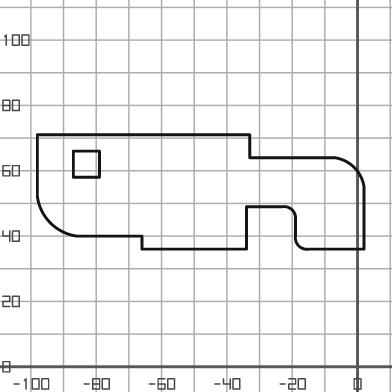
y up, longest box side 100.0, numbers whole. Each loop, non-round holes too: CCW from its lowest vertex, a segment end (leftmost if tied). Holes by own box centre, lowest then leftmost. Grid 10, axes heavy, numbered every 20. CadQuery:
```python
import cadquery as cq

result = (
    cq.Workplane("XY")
    .moveTo(-66.0, 36.0)
    .lineTo(-34.0, 36.0)
    .lineTo(-34.0, 49.0)
    .lineTo(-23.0, 49.0)
    .threePointArc((-20.0, 48.0), (-19.0, 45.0))
    .lineTo(-19.0, 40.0)
    .threePointArc((-18.0, 37.0), (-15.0, 36.0))
    .lineTo(2.0, 36.0)
    .lineTo(2.0, 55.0)
    .threePointArc((-1.0, 61.0), (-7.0, 64.0))
    .lineTo(-33.0, 64.0)
    .lineTo(-33.0, 71.0)
    .lineTo(-98.0, 71.0)
    .lineTo(-98.0, 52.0)
    .threePointArc((-94.0, 44.0), (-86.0, 40.0))
    .lineTo(-66.0, 40.0)
    .close()
    .moveTo(-87.0, 58.0)
    .lineTo(-79.0, 58.0)
    .lineTo(-79.0, 66.0)
    .lineTo(-87.0, 66.0)
    .close()
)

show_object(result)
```